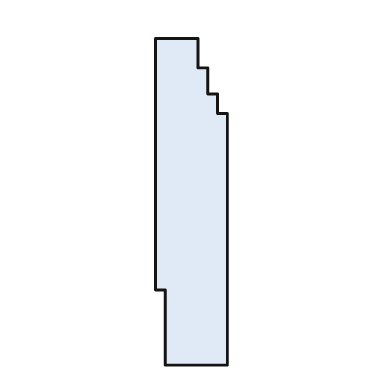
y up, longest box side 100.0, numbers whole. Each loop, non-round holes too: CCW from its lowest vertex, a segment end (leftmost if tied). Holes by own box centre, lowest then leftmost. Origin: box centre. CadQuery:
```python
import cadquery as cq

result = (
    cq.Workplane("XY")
    .moveTo(-8.0, -50.0)
    .lineTo(11.0, -50.0)
    .lineTo(11.0, 27.0)
    .lineTo(8.0, 27.0)
    .lineTo(8.0, 33.0)
    .lineTo(5.0, 33.0)
    .lineTo(5.0, 41.0)
    .lineTo(2.0, 41.0)
    .lineTo(2.0, 50.0)
    .lineTo(-11.0, 50.0)
    .lineTo(-11.0, -27.0)
    .lineTo(-8.0, -27.0)
    .close()
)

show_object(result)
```